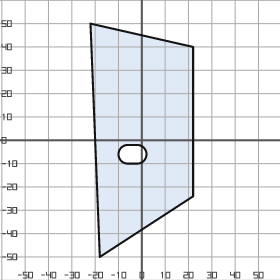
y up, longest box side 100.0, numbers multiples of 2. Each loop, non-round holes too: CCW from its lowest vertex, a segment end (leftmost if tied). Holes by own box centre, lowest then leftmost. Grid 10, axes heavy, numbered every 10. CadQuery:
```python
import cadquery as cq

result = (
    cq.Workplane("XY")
    .moveTo(-18.0, -50.0)
    .lineTo(22.0, -24.0)
    .lineTo(22.0, 40.0)
    .lineTo(-22.0, 50.0)
    .close()
    .moveTo(-6.0, -10.0)
    .lineTo(-2.0, -10.0)
    .threePointArc((2.0, -6.0), (-2.0, -2.0))
    .lineTo(-6.0, -2.0)
    .threePointArc((-10.0, -6.0), (-6.0, -10.0))
    .close()
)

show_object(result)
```